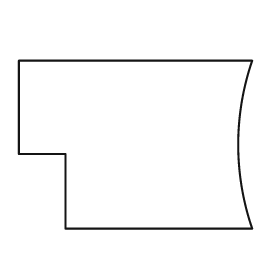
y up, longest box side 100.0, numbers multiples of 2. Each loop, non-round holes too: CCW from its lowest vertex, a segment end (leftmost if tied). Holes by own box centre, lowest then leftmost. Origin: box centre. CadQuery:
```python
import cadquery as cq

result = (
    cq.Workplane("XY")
    .moveTo(-30.0, -36.0)
    .lineTo(50.0, -36.0)
    .threePointArc((44.0, 0.0), (50.0, 36.0))
    .lineTo(-50.0, 36.0)
    .lineTo(-50.0, -4.0)
    .lineTo(-30.0, -4.0)
    .close()
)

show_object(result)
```